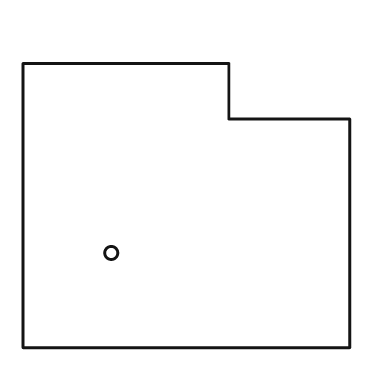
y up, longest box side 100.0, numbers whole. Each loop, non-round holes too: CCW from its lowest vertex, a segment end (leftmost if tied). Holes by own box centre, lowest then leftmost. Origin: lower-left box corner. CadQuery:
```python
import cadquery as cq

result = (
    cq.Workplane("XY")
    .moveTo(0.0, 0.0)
    .lineTo(100.0, 0.0)
    .lineTo(100.0, 70.0)
    .lineTo(63.0, 70.0)
    .lineTo(63.0, 87.0)
    .lineTo(0.0, 87.0)
    .close()
    .moveTo(27.0, 29.0)
    .circle(2.0)
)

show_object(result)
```